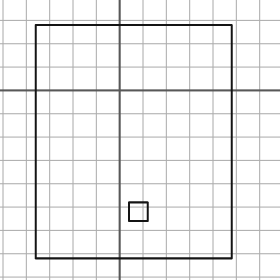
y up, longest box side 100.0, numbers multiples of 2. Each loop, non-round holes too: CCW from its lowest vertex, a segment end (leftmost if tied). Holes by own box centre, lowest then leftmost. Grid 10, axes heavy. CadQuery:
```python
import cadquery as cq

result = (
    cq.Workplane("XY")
    .moveTo(-36.0, -72.0)
    .lineTo(48.0, -72.0)
    .lineTo(48.0, 28.0)
    .lineTo(-36.0, 28.0)
    .close()
    .moveTo(4.0, -56.0)
    .lineTo(12.0, -56.0)
    .lineTo(12.0, -48.0)
    .lineTo(4.0, -48.0)
    .close()
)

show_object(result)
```